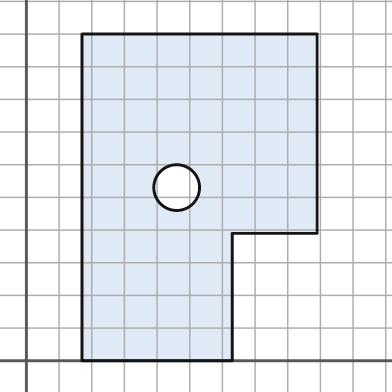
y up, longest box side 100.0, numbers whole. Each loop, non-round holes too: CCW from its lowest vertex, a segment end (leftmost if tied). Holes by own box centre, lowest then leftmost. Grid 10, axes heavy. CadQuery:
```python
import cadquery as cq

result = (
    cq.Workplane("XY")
    .moveTo(17.0, 0.0)
    .lineTo(63.0, 0.0)
    .lineTo(63.0, 39.0)
    .lineTo(89.0, 39.0)
    .lineTo(89.0, 100.0)
    .lineTo(17.0, 100.0)
    .close()
    .moveTo(46.0, 53.0)
    .circle(7.0)
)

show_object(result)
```